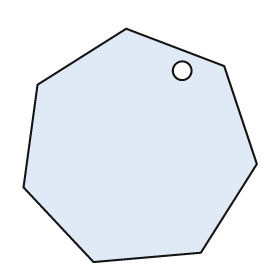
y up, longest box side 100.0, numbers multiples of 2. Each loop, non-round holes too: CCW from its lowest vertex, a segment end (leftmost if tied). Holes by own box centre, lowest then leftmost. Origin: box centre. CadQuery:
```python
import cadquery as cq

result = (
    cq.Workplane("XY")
    .moveTo(-20.0, -50.0)
    .lineTo(26.0, -46.0)
    .lineTo(50.0, -8.0)
    .lineTo(36.0, 34.0)
    .lineTo(-6.0, 50.0)
    .lineTo(-44.0, 26.0)
    .lineTo(-50.0, -18.0)
    .close()
    .moveTo(18.0, 32.0)
    .circle(4.0)
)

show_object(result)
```